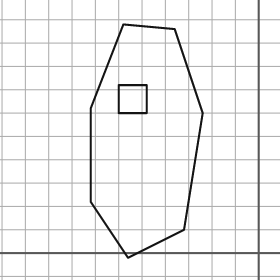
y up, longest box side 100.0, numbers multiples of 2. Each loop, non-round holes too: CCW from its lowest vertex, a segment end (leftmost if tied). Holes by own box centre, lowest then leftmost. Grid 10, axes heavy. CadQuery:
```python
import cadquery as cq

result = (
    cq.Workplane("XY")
    .moveTo(-56.0, -2.0)
    .lineTo(-32.0, 10.0)
    .lineTo(-24.0, 60.0)
    .lineTo(-36.0, 96.0)
    .lineTo(-58.0, 98.0)
    .lineTo(-72.0, 62.0)
    .lineTo(-72.0, 22.0)
    .close()
    .moveTo(-60.0, 60.0)
    .lineTo(-48.0, 60.0)
    .lineTo(-48.0, 72.0)
    .lineTo(-60.0, 72.0)
    .close()
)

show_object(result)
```